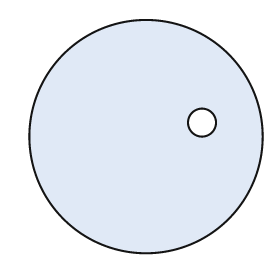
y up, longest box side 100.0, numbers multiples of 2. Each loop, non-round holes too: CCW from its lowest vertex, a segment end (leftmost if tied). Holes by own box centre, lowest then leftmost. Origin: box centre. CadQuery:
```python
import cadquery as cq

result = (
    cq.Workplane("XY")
    .moveTo(0.0, 0.0)
    .circle(50.0)
    .moveTo(24.0, 6.0)
    .circle(6.0)
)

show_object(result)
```